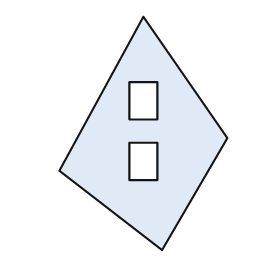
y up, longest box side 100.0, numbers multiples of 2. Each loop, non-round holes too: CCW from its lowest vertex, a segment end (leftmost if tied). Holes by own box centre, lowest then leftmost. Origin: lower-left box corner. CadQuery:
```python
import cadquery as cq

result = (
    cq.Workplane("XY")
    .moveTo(44.0, 0.0)
    .lineTo(72.0, 48.0)
    .lineTo(36.0, 100.0)
    .lineTo(0.0, 34.0)
    .close()
    .moveTo(30.0, 30.0)
    .lineTo(42.0, 30.0)
    .lineTo(42.0, 46.0)
    .lineTo(30.0, 46.0)
    .close()
    .moveTo(30.0, 56.0)
    .lineTo(42.0, 56.0)
    .lineTo(42.0, 72.0)
    .lineTo(30.0, 72.0)
    .close()
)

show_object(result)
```